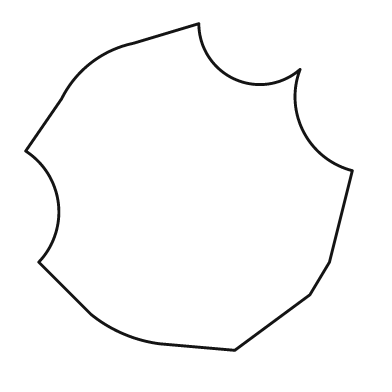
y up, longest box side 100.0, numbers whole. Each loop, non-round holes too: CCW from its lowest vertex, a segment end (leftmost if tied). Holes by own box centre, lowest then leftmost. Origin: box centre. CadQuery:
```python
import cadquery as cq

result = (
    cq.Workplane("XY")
    .moveTo(14.0, -50.0)
    .lineTo(37.0, -33.0)
    .lineTo(43.0, -23.0)
    .lineTo(50.0, 5.0)
    .threePointArc((35.0, 17.0), (34.0, 36.0))
    .threePointArc((14.0, 33.0), (3.0, 50.0))
    .lineTo(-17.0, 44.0)
    .threePointArc((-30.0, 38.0), (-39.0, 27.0))
    .lineTo(-50.0, 11.0)
    .threePointArc((-40.0, -5.0), (-46.0, -23.0))
    .lineTo(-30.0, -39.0)
    .threePointArc((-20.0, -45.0), (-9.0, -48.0))
    .close()
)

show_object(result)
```